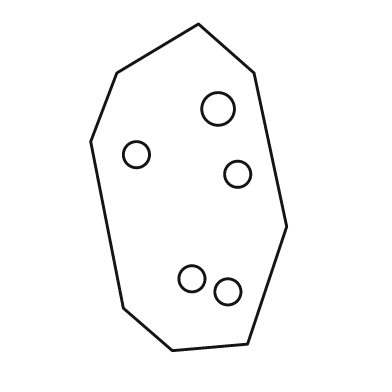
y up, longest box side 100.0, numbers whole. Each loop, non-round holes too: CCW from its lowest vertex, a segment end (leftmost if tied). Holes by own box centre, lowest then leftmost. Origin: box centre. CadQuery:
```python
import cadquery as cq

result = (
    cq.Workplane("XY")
    .moveTo(-5.0, -50.0)
    .lineTo(18.0, -48.0)
    .lineTo(30.0, -12.0)
    .lineTo(20.0, 35.0)
    .lineTo(3.0, 50.0)
    .lineTo(-22.0, 35.0)
    .lineTo(-30.0, 14.0)
    .lineTo(-20.0, -37.0)
    .close()
    .moveTo(12.0, -32.0)
    .circle(4.0)
    .moveTo(1.0, -28.0)
    .circle(4.0)
    .moveTo(15.0, 4.0)
    .circle(4.0)
    .moveTo(-16.0, 10.0)
    .circle(4.0)
    .moveTo(9.0, 24.0)
    .circle(5.0)
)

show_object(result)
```